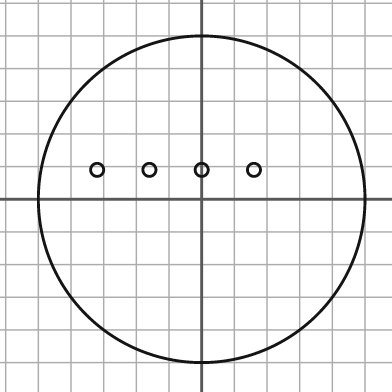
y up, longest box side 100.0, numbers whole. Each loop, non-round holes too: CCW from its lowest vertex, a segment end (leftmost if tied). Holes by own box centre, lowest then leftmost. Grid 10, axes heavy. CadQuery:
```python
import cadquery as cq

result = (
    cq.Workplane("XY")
    .moveTo(0.0, 0.0)
    .circle(50.0)
    .moveTo(-32.0, 9.0)
    .circle(2.0)
    .moveTo(-16.0, 9.0)
    .circle(2.0)
    .moveTo(0.0, 9.0)
    .circle(2.0)
    .moveTo(16.0, 9.0)
    .circle(2.0)
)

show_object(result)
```